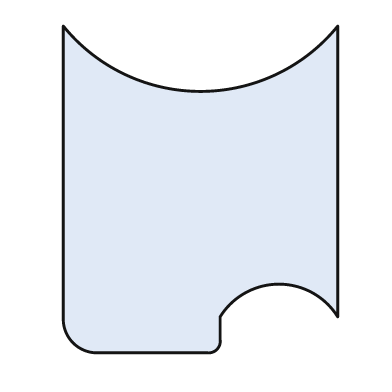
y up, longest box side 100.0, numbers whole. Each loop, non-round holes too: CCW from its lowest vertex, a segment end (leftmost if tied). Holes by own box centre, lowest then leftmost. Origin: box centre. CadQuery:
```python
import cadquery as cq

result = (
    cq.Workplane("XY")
    .moveTo(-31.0, -50.0)
    .lineTo(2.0, -50.0)
    .threePointArc((5.0, -49.0), (6.0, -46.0))
    .lineTo(6.0, -39.0)
    .threePointArc((24.0, -29.0), (42.0, -39.0))
    .lineTo(42.0, 50.0)
    .threePointArc((0.0, 30.0), (-42.0, 50.0))
    .lineTo(-42.0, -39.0)
    .threePointArc((-39.0, -47.0), (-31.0, -50.0))
    .close()
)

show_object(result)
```